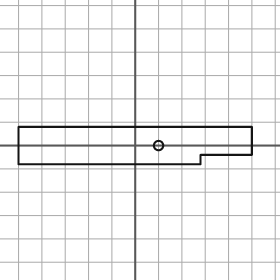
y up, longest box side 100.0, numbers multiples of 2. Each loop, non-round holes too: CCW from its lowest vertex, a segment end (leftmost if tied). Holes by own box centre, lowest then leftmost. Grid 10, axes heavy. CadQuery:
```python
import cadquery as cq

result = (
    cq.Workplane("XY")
    .moveTo(-50.0, -8.0)
    .lineTo(28.0, -8.0)
    .lineTo(28.0, -4.0)
    .lineTo(50.0, -4.0)
    .lineTo(50.0, 8.0)
    .lineTo(-50.0, 8.0)
    .close()
    .moveTo(10.0, 0.0)
    .circle(2.0)
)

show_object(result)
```